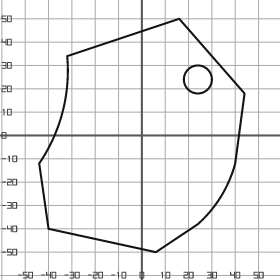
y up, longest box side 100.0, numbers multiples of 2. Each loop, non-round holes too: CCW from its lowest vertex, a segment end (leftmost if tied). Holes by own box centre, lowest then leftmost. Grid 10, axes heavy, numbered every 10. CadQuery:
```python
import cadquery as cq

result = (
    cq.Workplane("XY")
    .moveTo(6.0, -50.0)
    .lineTo(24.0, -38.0)
    .threePointArc((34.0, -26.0), (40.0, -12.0))
    .lineTo(44.0, 18.0)
    .lineTo(16.0, 50.0)
    .lineTo(-32.0, 34.0)
    .threePointArc((-34.0, 10.0), (-44.0, -12.0))
    .lineTo(-40.0, -40.0)
    .close()
    .moveTo(24.0, 24.0)
    .circle(6.0)
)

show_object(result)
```